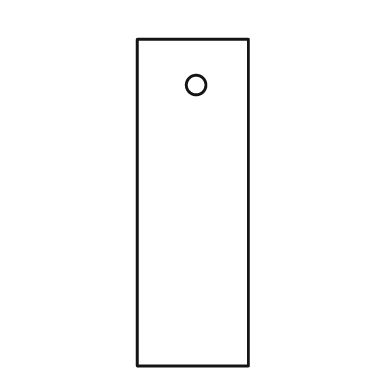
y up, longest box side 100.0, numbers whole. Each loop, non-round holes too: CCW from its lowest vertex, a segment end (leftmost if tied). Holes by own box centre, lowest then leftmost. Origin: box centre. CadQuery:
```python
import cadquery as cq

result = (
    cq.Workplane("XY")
    .moveTo(-17.0, -50.0)
    .lineTo(17.0, -50.0)
    .lineTo(17.0, 50.0)
    .lineTo(-17.0, 50.0)
    .close()
    .moveTo(1.0, 36.0)
    .circle(3.0)
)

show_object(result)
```